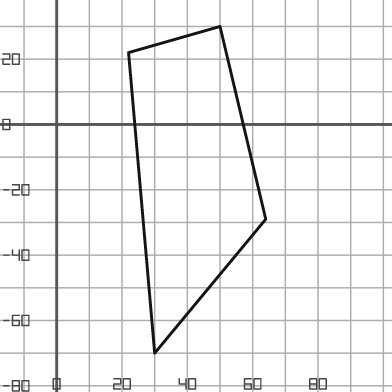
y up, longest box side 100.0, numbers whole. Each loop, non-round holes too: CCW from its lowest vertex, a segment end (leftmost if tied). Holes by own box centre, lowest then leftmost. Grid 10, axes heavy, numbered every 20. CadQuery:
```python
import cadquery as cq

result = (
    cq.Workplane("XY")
    .moveTo(30.0, -70.0)
    .lineTo(64.0, -29.0)
    .lineTo(50.0, 30.0)
    .lineTo(22.0, 22.0)
    .close()
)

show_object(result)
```